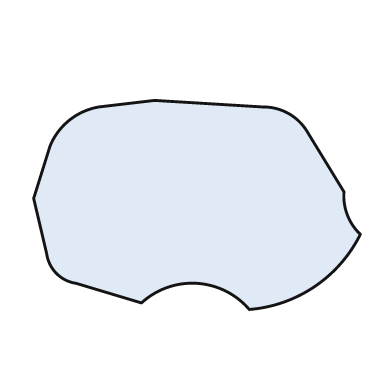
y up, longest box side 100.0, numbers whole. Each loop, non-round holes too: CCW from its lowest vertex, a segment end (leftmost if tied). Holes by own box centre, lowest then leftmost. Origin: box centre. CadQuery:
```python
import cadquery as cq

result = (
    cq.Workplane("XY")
    .moveTo(16.0, -32.0)
    .threePointArc((36.0, -25.0), (50.0, -9.0))
    .threePointArc((46.0, -3.0), (45.0, 4.0))
    .lineTo(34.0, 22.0)
    .threePointArc((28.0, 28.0), (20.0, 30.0))
    .lineTo(-13.0, 32.0)
    .lineTo(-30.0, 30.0)
    .threePointArc((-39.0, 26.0), (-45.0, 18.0))
    .lineTo(-50.0, 2.0)
    .lineTo(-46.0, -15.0)
    .threePointArc((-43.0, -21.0), (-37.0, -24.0))
    .lineTo(-17.0, -30.0)
    .threePointArc((0.0, -24.0), (16.0, -32.0))
    .close()
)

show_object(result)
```